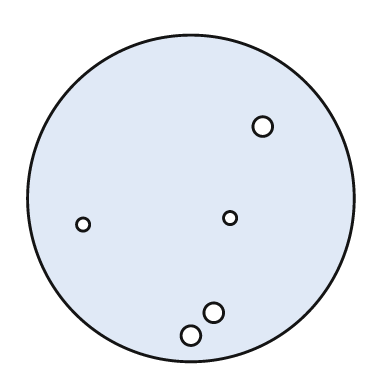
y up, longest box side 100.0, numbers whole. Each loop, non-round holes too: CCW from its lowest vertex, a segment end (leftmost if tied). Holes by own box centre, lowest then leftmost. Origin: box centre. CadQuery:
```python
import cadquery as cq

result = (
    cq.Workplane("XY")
    .moveTo(0.0, 0.0)
    .circle(50.0)
    .moveTo(0.0, -42.0)
    .circle(3.0)
    .moveTo(7.0, -35.0)
    .circle(3.0)
    .moveTo(-33.0, -8.0)
    .circle(2.0)
    .moveTo(12.0, -6.0)
    .circle(2.0)
    .moveTo(22.0, 22.0)
    .circle(3.0)
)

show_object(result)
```